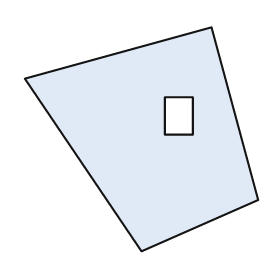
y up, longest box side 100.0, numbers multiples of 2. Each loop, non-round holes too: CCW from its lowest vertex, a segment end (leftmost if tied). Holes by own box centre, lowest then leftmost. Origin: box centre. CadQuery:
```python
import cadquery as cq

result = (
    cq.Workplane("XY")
    .moveTo(0.0, -48.0)
    .lineTo(50.0, -26.0)
    .lineTo(30.0, 48.0)
    .lineTo(-50.0, 26.0)
    .close()
    .moveTo(10.0, 2.0)
    .lineTo(22.0, 2.0)
    .lineTo(22.0, 18.0)
    .lineTo(10.0, 18.0)
    .close()
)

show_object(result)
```